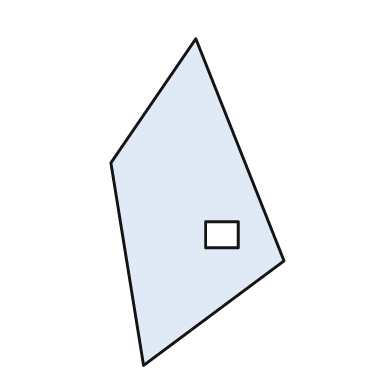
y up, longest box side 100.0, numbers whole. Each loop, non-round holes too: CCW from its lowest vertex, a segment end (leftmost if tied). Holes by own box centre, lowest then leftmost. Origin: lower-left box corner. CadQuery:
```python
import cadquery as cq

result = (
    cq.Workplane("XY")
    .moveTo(10.0, 0.0)
    .lineTo(53.0, 32.0)
    .lineTo(26.0, 100.0)
    .lineTo(0.0, 62.0)
    .close()
    .moveTo(29.0, 36.0)
    .lineTo(39.0, 36.0)
    .lineTo(39.0, 44.0)
    .lineTo(29.0, 44.0)
    .close()
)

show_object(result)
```